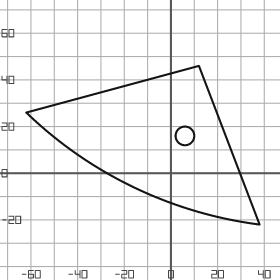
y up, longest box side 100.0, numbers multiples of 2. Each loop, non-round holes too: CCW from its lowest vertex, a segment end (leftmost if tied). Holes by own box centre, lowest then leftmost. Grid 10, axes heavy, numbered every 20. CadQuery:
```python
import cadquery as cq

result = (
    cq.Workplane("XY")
    .moveTo(38.0, -22.0)
    .lineTo(12.0, 46.0)
    .lineTo(-62.0, 26.0)
    .threePointArc((-16.0, -6.0), (38.0, -22.0))
    .close()
    .moveTo(6.0, 16.0)
    .circle(4.0)
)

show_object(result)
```